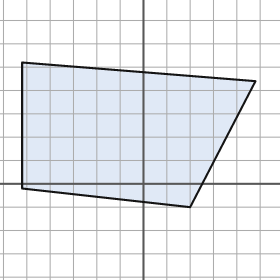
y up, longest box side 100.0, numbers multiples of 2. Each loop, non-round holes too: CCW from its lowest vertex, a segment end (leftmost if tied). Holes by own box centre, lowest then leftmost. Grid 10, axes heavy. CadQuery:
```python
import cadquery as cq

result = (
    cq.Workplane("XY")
    .moveTo(20.0, -10.0)
    .lineTo(48.0, 44.0)
    .lineTo(-52.0, 52.0)
    .lineTo(-52.0, -2.0)
    .close()
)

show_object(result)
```